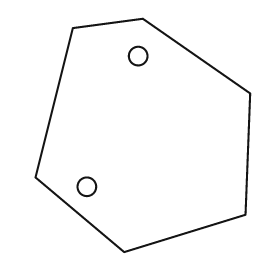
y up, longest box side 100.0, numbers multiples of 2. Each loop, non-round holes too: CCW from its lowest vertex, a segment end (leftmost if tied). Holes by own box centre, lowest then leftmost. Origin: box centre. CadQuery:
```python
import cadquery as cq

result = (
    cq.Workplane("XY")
    .moveTo(-8.0, -50.0)
    .lineTo(44.0, -34.0)
    .lineTo(46.0, 18.0)
    .lineTo(0.0, 50.0)
    .lineTo(-30.0, 46.0)
    .lineTo(-46.0, -18.0)
    .close()
    .moveTo(-24.0, -22.0)
    .circle(4.0)
    .moveTo(-2.0, 34.0)
    .circle(4.0)
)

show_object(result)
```